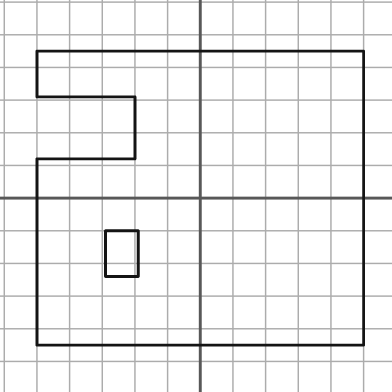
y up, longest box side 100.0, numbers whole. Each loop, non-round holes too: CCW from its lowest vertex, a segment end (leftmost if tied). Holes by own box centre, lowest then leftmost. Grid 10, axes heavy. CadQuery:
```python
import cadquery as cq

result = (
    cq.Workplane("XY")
    .moveTo(-50.0, -45.0)
    .lineTo(50.0, -45.0)
    .lineTo(50.0, 45.0)
    .lineTo(-50.0, 45.0)
    .lineTo(-50.0, 31.0)
    .lineTo(-20.0, 31.0)
    .lineTo(-20.0, 12.0)
    .lineTo(-50.0, 12.0)
    .close()
    .moveTo(-29.0, -24.0)
    .lineTo(-19.0, -24.0)
    .lineTo(-19.0, -10.0)
    .lineTo(-29.0, -10.0)
    .close()
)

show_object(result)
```